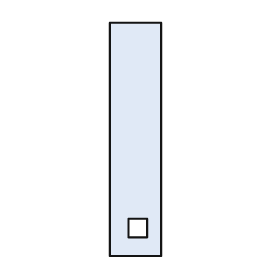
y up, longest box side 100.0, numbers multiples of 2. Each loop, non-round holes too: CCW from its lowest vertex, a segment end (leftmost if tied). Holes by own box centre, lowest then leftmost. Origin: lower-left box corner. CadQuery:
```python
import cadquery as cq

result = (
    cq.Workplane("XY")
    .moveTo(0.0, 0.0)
    .lineTo(22.0, 0.0)
    .lineTo(22.0, 100.0)
    .lineTo(0.0, 100.0)
    .close()
    .moveTo(8.0, 8.0)
    .lineTo(16.0, 8.0)
    .lineTo(16.0, 16.0)
    .lineTo(8.0, 16.0)
    .close()
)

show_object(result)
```